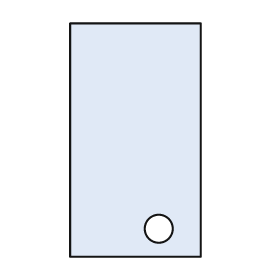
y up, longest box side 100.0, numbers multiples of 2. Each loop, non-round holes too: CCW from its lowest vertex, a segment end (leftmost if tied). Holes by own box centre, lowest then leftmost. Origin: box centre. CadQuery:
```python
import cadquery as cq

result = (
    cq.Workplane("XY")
    .moveTo(-28.0, -50.0)
    .lineTo(28.0, -50.0)
    .lineTo(28.0, 50.0)
    .lineTo(-28.0, 50.0)
    .close()
    .moveTo(10.0, -38.0)
    .circle(6.0)
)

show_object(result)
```